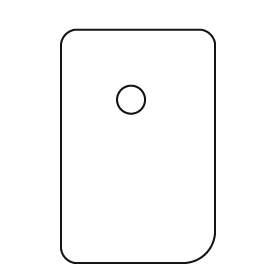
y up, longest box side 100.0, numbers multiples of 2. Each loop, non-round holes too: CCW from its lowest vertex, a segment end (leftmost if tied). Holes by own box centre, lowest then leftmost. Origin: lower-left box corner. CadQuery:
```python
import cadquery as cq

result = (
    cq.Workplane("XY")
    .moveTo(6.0, 0.0)
    .lineTo(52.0, 0.0)
    .threePointArc((62.0, 4.0), (66.0, 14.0))
    .lineTo(66.0, 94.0)
    .threePointArc((64.0, 98.0), (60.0, 100.0))
    .lineTo(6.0, 100.0)
    .threePointArc((2.0, 98.0), (0.0, 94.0))
    .lineTo(0.0, 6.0)
    .threePointArc((2.0, 2.0), (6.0, 0.0))
    .close()
    .moveTo(30.0, 70.0)
    .circle(6.0)
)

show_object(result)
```